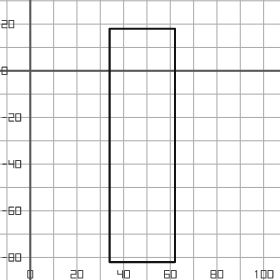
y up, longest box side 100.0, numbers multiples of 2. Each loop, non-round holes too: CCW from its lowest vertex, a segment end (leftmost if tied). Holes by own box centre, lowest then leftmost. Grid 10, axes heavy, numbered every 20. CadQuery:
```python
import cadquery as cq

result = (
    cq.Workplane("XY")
    .moveTo(34.0, -82.0)
    .lineTo(62.0, -82.0)
    .lineTo(62.0, 18.0)
    .lineTo(34.0, 18.0)
    .close()
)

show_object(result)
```